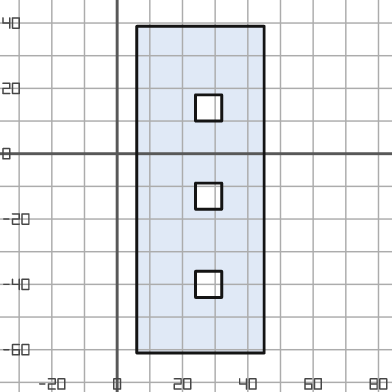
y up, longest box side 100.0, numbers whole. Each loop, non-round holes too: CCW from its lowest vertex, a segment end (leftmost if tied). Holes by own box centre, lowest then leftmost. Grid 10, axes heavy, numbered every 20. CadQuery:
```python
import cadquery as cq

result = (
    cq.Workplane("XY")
    .moveTo(6.0, -61.0)
    .lineTo(45.0, -61.0)
    .lineTo(45.0, 39.0)
    .lineTo(6.0, 39.0)
    .close()
    .moveTo(24.0, -44.0)
    .lineTo(32.0, -44.0)
    .lineTo(32.0, -36.0)
    .lineTo(24.0, -36.0)
    .close()
    .moveTo(24.0, -17.0)
    .lineTo(32.0, -17.0)
    .lineTo(32.0, -9.0)
    .lineTo(24.0, -9.0)
    .close()
    .moveTo(24.0, 10.0)
    .lineTo(32.0, 10.0)
    .lineTo(32.0, 18.0)
    .lineTo(24.0, 18.0)
    .close()
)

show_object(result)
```